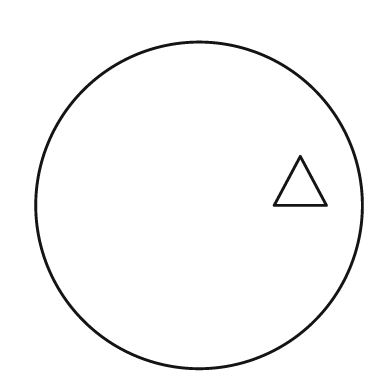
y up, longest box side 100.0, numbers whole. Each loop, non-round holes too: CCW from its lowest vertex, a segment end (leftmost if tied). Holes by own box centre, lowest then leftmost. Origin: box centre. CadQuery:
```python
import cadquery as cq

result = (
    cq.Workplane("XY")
    .moveTo(0.0, 0.0)
    .circle(50.0)
    .moveTo(23.0, 0.0)
    .lineTo(39.0, 0.0)
    .lineTo(31.0, 15.0)
    .close()
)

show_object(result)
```